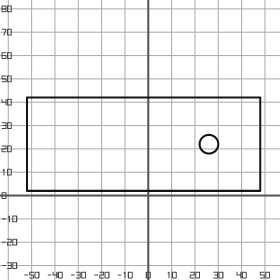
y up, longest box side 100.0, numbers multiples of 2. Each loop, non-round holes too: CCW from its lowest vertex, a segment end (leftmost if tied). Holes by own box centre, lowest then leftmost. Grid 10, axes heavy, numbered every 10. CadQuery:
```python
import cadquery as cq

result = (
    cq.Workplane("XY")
    .moveTo(-52.0, 2.0)
    .lineTo(48.0, 2.0)
    .lineTo(48.0, 42.0)
    .lineTo(-52.0, 42.0)
    .close()
    .moveTo(26.0, 22.0)
    .circle(4.0)
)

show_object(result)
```